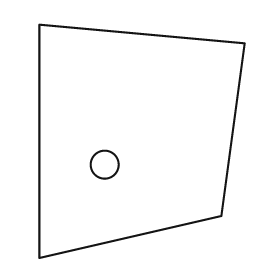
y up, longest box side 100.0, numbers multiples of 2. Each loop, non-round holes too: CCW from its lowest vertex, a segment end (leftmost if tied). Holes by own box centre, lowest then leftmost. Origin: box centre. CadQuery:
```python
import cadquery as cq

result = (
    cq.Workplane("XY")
    .moveTo(-44.0, -50.0)
    .lineTo(34.0, -32.0)
    .lineTo(44.0, 42.0)
    .lineTo(-44.0, 50.0)
    .close()
    .moveTo(-16.0, -10.0)
    .circle(6.0)
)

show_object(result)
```